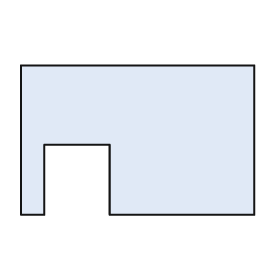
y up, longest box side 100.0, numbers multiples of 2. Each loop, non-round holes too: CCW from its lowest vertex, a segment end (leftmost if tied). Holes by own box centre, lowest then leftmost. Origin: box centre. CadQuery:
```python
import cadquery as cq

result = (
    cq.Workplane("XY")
    .moveTo(-50.0, -32.0)
    .lineTo(-40.0, -32.0)
    .lineTo(-40.0, -2.0)
    .lineTo(-12.0, -2.0)
    .lineTo(-12.0, -32.0)
    .lineTo(50.0, -32.0)
    .lineTo(50.0, 32.0)
    .lineTo(-50.0, 32.0)
    .close()
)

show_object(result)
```